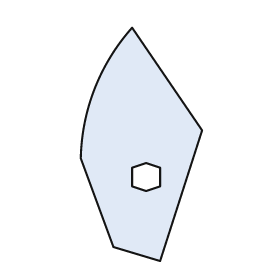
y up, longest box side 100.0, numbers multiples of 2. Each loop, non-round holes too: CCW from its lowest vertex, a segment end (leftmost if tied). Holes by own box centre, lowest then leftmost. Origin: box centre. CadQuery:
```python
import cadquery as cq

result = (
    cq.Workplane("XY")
    .moveTo(8.0, -50.0)
    .lineTo(26.0, 6.0)
    .lineTo(-4.0, 50.0)
    .threePointArc((-20.0, 24.0), (-26.0, -6.0))
    .lineTo(-12.0, -44.0)
    .close()
    .moveTo(2.0, -20.0)
    .lineTo(8.0, -18.0)
    .lineTo(8.0, -10.0)
    .lineTo(2.0, -8.0)
    .lineTo(-4.0, -10.0)
    .lineTo(-4.0, -18.0)
    .close()
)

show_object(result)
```